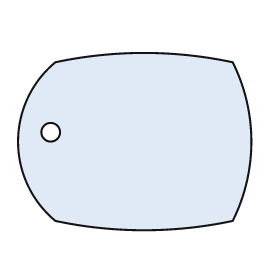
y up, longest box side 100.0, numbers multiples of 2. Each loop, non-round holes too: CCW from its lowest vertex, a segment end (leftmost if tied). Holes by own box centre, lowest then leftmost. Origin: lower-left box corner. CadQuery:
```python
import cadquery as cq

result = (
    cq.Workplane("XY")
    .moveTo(16.0, 4.0)
    .threePointArc((54.0, 0.0), (92.0, 4.0))
    .threePointArc((100.0, 38.0), (92.0, 72.0))
    .threePointArc((54.0, 76.0), (16.0, 72.0))
    .threePointArc((0.0, 38.0), (16.0, 4.0))
    .close()
    .moveTo(14.0, 42.0)
    .circle(4.0)
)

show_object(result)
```